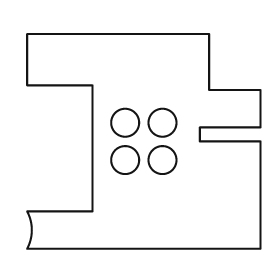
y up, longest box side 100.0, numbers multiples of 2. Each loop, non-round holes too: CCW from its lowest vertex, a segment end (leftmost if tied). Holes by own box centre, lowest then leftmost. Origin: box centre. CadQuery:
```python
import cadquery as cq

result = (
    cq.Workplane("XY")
    .moveTo(-50.0, -46.0)
    .lineTo(50.0, -46.0)
    .lineTo(50.0, 0.0)
    .lineTo(24.0, 0.0)
    .lineTo(24.0, 6.0)
    .lineTo(50.0, 6.0)
    .lineTo(50.0, 22.0)
    .lineTo(28.0, 22.0)
    .lineTo(28.0, 46.0)
    .lineTo(-50.0, 46.0)
    .lineTo(-50.0, 24.0)
    .lineTo(-22.0, 24.0)
    .lineTo(-22.0, -30.0)
    .lineTo(-50.0, -30.0)
    .threePointArc((-48.0, -38.0), (-50.0, -46.0))
    .close()
    .moveTo(-8.0, -8.0)
    .circle(6.0)
    .moveTo(8.0, -8.0)
    .circle(6.0)
    .moveTo(-8.0, 8.0)
    .circle(6.0)
    .moveTo(8.0, 8.0)
    .circle(6.0)
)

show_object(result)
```